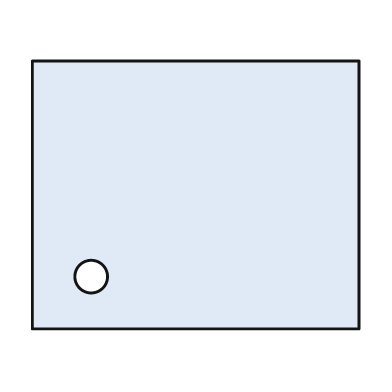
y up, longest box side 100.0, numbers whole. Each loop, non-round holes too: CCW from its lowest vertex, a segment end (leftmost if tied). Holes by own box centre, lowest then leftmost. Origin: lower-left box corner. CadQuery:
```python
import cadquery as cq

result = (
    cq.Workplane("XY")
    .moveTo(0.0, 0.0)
    .lineTo(100.0, 0.0)
    .lineTo(100.0, 82.0)
    .lineTo(0.0, 82.0)
    .close()
    .moveTo(18.0, 16.0)
    .circle(5.0)
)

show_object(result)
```